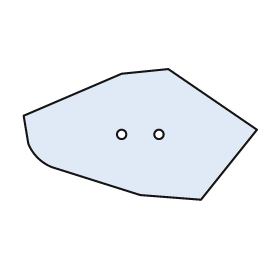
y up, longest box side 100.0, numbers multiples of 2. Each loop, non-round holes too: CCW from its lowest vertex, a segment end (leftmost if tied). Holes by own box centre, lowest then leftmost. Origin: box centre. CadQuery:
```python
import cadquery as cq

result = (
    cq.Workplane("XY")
    .moveTo(26.0, -28.0)
    .lineTo(50.0, 2.0)
    .lineTo(12.0, 28.0)
    .lineTo(-8.0, 26.0)
    .lineTo(-50.0, 8.0)
    .lineTo(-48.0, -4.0)
    .threePointArc((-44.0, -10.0), (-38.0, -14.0))
    .lineTo(0.0, -26.0)
    .close()
    .moveTo(-8.0, 0.0)
    .circle(2.0)
    .moveTo(8.0, 0.0)
    .circle(2.0)
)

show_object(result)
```